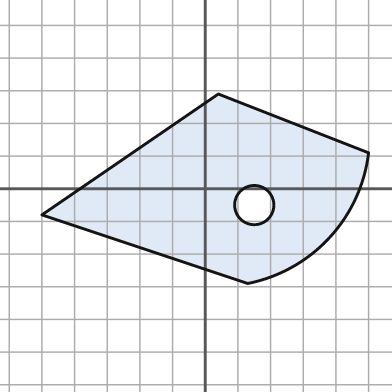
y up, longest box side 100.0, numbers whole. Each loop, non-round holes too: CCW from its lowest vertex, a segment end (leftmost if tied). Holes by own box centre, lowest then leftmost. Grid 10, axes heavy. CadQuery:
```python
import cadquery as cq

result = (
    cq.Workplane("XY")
    .moveTo(13.0, -29.0)
    .threePointArc((38.0, -15.0), (50.0, 11.0))
    .lineTo(4.0, 29.0)
    .lineTo(-50.0, -8.0)
    .close()
    .moveTo(15.0, -5.0)
    .circle(6.0)
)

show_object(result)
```